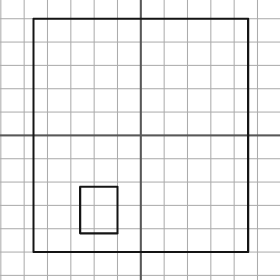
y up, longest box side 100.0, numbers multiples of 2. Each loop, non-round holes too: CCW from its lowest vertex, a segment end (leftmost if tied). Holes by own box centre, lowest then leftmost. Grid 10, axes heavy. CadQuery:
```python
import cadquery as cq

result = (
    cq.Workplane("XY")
    .moveTo(-46.0, -50.0)
    .lineTo(46.0, -50.0)
    .lineTo(46.0, 50.0)
    .lineTo(-46.0, 50.0)
    .close()
    .moveTo(-26.0, -42.0)
    .lineTo(-10.0, -42.0)
    .lineTo(-10.0, -22.0)
    .lineTo(-26.0, -22.0)
    .close()
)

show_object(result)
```